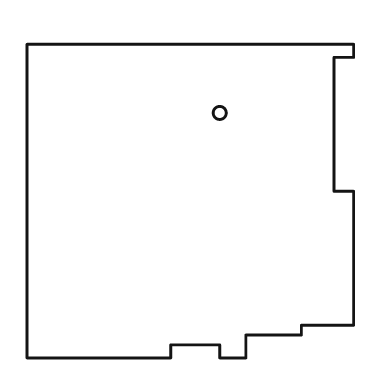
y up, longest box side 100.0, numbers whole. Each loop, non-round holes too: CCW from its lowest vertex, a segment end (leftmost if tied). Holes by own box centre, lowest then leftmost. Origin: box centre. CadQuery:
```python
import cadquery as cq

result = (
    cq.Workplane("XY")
    .moveTo(-50.0, -48.0)
    .lineTo(-6.0, -48.0)
    .lineTo(-6.0, -44.0)
    .lineTo(9.0, -44.0)
    .lineTo(9.0, -48.0)
    .lineTo(17.0, -48.0)
    .lineTo(17.0, -41.0)
    .lineTo(34.0, -41.0)
    .lineTo(34.0, -38.0)
    .lineTo(50.0, -38.0)
    .lineTo(50.0, 3.0)
    .lineTo(44.0, 3.0)
    .lineTo(44.0, 44.0)
    .lineTo(50.0, 44.0)
    .lineTo(50.0, 48.0)
    .lineTo(-50.0, 48.0)
    .close()
    .moveTo(9.0, 27.0)
    .circle(2.0)
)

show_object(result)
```